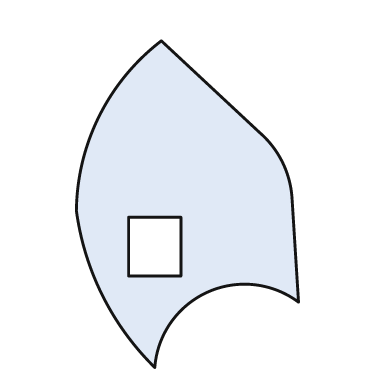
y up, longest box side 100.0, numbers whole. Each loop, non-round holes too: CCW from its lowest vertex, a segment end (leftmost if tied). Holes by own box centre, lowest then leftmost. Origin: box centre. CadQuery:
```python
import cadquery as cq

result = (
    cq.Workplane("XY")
    .moveTo(-10.0, -50.0)
    .threePointArc((6.0, -27.0), (34.0, -30.0))
    .lineTo(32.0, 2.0)
    .threePointArc((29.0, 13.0), (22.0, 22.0))
    .lineTo(-8.0, 50.0)
    .threePointArc((-27.0, 27.0), (-34.0, -2.0))
    .threePointArc((-26.0, -28.0), (-10.0, -50.0))
    .close()
    .moveTo(-18.0, -22.0)
    .lineTo(-2.0, -22.0)
    .lineTo(-2.0, -4.0)
    .lineTo(-18.0, -4.0)
    .close()
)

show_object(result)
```